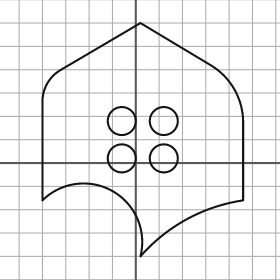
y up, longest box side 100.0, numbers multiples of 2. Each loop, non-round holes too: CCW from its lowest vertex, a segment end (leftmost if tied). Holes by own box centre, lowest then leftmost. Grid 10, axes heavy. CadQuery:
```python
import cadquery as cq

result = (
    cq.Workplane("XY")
    .moveTo(2.0, -40.0)
    .threePointArc((22.0, -24.0), (46.0, -16.0))
    .lineTo(46.0, 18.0)
    .threePointArc((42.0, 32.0), (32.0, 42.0))
    .lineTo(2.0, 60.0)
    .lineTo(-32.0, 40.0)
    .threePointArc((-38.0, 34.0), (-40.0, 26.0))
    .lineTo(-40.0, -16.0)
    .threePointArc((-10.0, -12.0), (2.0, -40.0))
    .close()
    .moveTo(-6.0, 2.0)
    .circle(6.0)
    .moveTo(12.0, 2.0)
    .circle(6.0)
    .moveTo(-6.0, 18.0)
    .circle(6.0)
    .moveTo(12.0, 18.0)
    .circle(6.0)
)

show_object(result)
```